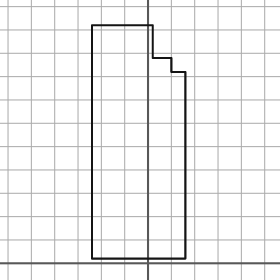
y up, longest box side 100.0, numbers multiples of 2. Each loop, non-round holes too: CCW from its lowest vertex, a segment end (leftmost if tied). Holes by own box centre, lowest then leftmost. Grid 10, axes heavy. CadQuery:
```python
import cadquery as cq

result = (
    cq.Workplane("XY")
    .moveTo(-24.0, 2.0)
    .lineTo(16.0, 2.0)
    .lineTo(16.0, 82.0)
    .lineTo(10.0, 82.0)
    .lineTo(10.0, 88.0)
    .lineTo(2.0, 88.0)
    .lineTo(2.0, 102.0)
    .lineTo(-24.0, 102.0)
    .close()
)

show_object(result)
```